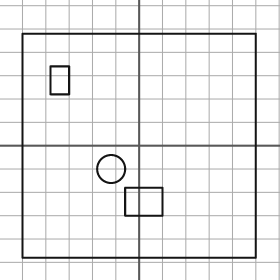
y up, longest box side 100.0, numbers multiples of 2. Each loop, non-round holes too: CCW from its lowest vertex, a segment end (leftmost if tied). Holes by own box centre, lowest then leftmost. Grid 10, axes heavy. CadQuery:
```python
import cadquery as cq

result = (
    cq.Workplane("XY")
    .moveTo(-50.0, -48.0)
    .lineTo(50.0, -48.0)
    .lineTo(50.0, 48.0)
    .lineTo(-50.0, 48.0)
    .close()
    .moveTo(-6.0, -30.0)
    .lineTo(10.0, -30.0)
    .lineTo(10.0, -18.0)
    .lineTo(-6.0, -18.0)
    .close()
    .moveTo(-12.0, -10.0)
    .circle(6.0)
    .moveTo(-38.0, 22.0)
    .lineTo(-30.0, 22.0)
    .lineTo(-30.0, 34.0)
    .lineTo(-38.0, 34.0)
    .close()
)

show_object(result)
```